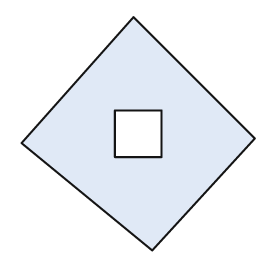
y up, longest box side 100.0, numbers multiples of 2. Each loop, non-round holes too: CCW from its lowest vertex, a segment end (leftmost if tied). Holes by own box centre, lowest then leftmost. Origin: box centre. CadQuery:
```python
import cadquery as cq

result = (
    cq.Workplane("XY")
    .moveTo(6.0, -50.0)
    .lineTo(50.0, -2.0)
    .lineTo(-2.0, 50.0)
    .lineTo(-50.0, -4.0)
    .close()
    .moveTo(-10.0, -10.0)
    .lineTo(10.0, -10.0)
    .lineTo(10.0, 10.0)
    .lineTo(-10.0, 10.0)
    .close()
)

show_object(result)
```